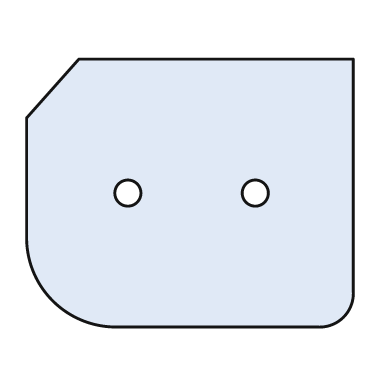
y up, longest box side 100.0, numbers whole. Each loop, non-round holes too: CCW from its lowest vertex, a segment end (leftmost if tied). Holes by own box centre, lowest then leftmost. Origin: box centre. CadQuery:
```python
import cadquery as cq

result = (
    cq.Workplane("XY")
    .moveTo(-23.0, -41.0)
    .lineTo(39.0, -41.0)
    .threePointArc((47.0, -38.0), (50.0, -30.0))
    .lineTo(50.0, 41.0)
    .lineTo(-34.0, 41.0)
    .lineTo(-50.0, 23.0)
    .lineTo(-50.0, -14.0)
    .threePointArc((-42.0, -33.0), (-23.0, -41.0))
    .close()
    .moveTo(-19.0, 0.0)
    .circle(4.0)
    .moveTo(20.0, 0.0)
    .circle(4.0)
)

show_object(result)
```